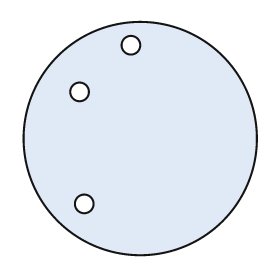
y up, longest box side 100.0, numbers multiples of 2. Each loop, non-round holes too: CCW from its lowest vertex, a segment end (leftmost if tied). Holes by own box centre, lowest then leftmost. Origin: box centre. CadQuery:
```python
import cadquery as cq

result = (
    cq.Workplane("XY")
    .moveTo(0.0, 0.0)
    .circle(50.0)
    .moveTo(-24.0, -28.0)
    .circle(4.0)
    .moveTo(-26.0, 20.0)
    .circle(4.0)
    .moveTo(-4.0, 40.0)
    .circle(4.0)
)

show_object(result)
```